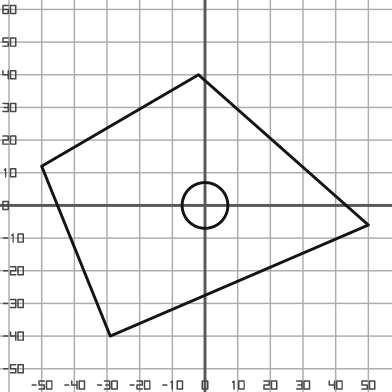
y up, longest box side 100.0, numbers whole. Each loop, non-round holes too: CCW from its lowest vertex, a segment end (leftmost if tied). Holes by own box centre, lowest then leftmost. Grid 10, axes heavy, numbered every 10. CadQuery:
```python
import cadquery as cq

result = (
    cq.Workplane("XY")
    .moveTo(-29.0, -40.0)
    .lineTo(50.0, -6.0)
    .lineTo(-2.0, 40.0)
    .lineTo(-50.0, 12.0)
    .close()
    .moveTo(0.0, 0.0)
    .circle(7.0)
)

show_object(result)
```